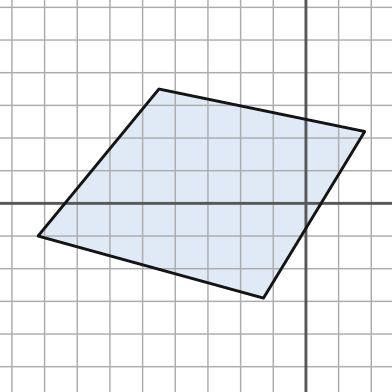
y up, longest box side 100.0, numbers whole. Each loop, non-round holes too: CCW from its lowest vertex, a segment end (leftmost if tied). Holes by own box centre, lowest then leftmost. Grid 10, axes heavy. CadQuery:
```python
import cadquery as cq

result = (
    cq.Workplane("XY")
    .moveTo(-13.0, -29.0)
    .lineTo(18.0, 22.0)
    .lineTo(-45.0, 35.0)
    .lineTo(-82.0, -10.0)
    .close()
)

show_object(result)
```